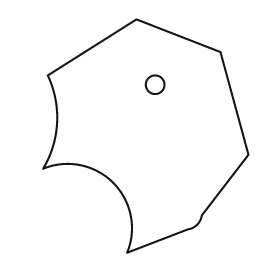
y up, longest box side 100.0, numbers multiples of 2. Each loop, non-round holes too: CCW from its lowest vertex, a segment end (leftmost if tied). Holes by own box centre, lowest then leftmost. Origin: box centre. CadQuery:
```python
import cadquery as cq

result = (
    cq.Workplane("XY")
    .moveTo(-8.0, -50.0)
    .lineTo(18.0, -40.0)
    .threePointArc((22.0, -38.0), (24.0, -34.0))
    .lineTo(44.0, -8.0)
    .lineTo(32.0, 36.0)
    .lineTo(-4.0, 50.0)
    .lineTo(-42.0, 26.0)
    .threePointArc((-38.0, 6.0), (-44.0, -14.0))
    .threePointArc((-14.0, -20.0), (-8.0, -50.0))
    .close()
    .moveTo(4.0, 22.0)
    .circle(4.0)
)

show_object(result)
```